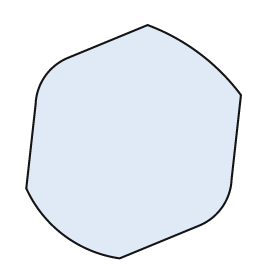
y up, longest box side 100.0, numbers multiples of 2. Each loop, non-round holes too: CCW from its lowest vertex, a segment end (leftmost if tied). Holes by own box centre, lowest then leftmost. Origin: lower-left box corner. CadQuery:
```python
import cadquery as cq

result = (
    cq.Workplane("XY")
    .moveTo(40.0, 0.0)
    .lineTo(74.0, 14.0)
    .threePointArc((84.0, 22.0), (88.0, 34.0))
    .lineTo(92.0, 70.0)
    .threePointArc((74.0, 88.0), (52.0, 100.0))
    .lineTo(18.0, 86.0)
    .threePointArc((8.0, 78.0), (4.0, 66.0))
    .lineTo(0.0, 30.0)
    .threePointArc((16.0, 10.0), (40.0, 0.0))
    .close()
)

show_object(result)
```